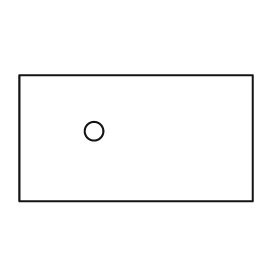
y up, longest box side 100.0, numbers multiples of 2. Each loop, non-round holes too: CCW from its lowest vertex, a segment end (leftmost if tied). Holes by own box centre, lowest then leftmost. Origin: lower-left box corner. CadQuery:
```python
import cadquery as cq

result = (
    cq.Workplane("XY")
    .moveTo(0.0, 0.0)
    .lineTo(100.0, 0.0)
    .lineTo(100.0, 54.0)
    .lineTo(0.0, 54.0)
    .close()
    .moveTo(32.0, 30.0)
    .circle(4.0)
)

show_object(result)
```